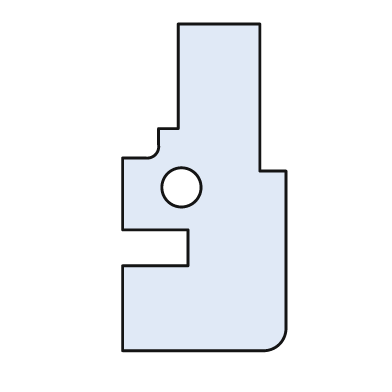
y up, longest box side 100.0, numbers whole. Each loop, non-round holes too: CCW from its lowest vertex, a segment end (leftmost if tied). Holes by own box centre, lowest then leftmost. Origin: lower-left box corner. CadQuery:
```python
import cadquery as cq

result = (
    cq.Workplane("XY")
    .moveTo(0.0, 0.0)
    .lineTo(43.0, 0.0)
    .threePointArc((48.0, 2.0), (50.0, 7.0))
    .lineTo(50.0, 55.0)
    .lineTo(42.0, 55.0)
    .lineTo(42.0, 100.0)
    .lineTo(17.0, 100.0)
    .lineTo(17.0, 68.0)
    .lineTo(11.0, 68.0)
    .lineTo(11.0, 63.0)
    .threePointArc((10.0, 60.0), (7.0, 59.0))
    .lineTo(0.0, 59.0)
    .lineTo(0.0, 37.0)
    .lineTo(20.0, 37.0)
    .lineTo(20.0, 26.0)
    .lineTo(0.0, 26.0)
    .close()
    .moveTo(18.0, 50.0)
    .circle(6.0)
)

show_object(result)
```